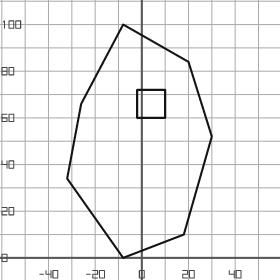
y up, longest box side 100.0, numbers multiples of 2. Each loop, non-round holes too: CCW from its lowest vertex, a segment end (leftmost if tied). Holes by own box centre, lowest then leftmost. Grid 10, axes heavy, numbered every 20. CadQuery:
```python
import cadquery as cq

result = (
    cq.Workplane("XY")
    .moveTo(-8.0, 0.0)
    .lineTo(18.0, 10.0)
    .lineTo(30.0, 52.0)
    .lineTo(20.0, 84.0)
    .lineTo(-8.0, 100.0)
    .lineTo(-26.0, 66.0)
    .lineTo(-32.0, 34.0)
    .close()
    .moveTo(-2.0, 60.0)
    .lineTo(10.0, 60.0)
    .lineTo(10.0, 72.0)
    .lineTo(-2.0, 72.0)
    .close()
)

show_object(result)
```